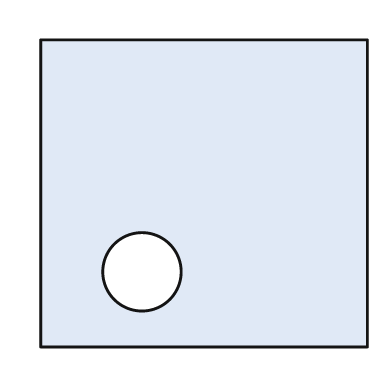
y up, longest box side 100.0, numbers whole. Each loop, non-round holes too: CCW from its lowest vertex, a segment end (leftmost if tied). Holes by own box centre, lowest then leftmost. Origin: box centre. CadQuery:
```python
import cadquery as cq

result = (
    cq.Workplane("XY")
    .moveTo(-50.0, -47.0)
    .lineTo(50.0, -47.0)
    .lineTo(50.0, 47.0)
    .lineTo(-50.0, 47.0)
    .close()
    .moveTo(-19.0, -24.0)
    .circle(12.0)
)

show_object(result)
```